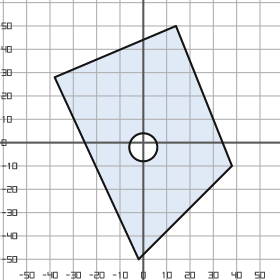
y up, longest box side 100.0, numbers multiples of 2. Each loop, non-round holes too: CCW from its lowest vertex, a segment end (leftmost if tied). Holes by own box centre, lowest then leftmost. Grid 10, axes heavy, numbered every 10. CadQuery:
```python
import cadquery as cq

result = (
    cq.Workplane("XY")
    .moveTo(-2.0, -50.0)
    .lineTo(38.0, -10.0)
    .lineTo(14.0, 50.0)
    .lineTo(-38.0, 28.0)
    .close()
    .moveTo(0.0, -2.0)
    .circle(6.0)
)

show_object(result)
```